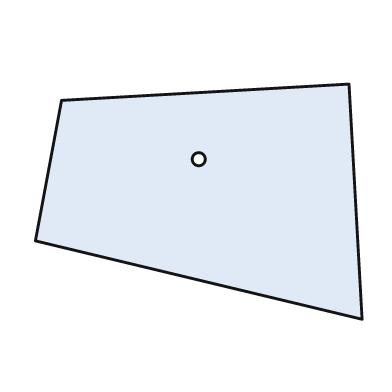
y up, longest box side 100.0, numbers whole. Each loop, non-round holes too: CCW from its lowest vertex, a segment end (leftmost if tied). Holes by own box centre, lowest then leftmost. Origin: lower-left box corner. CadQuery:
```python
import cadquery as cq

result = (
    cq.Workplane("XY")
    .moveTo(100.0, 0.0)
    .lineTo(96.0, 72.0)
    .lineTo(8.0, 67.0)
    .lineTo(0.0, 24.0)
    .close()
    .moveTo(50.0, 49.0)
    .circle(2.0)
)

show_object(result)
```